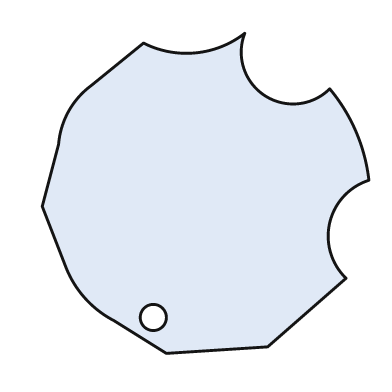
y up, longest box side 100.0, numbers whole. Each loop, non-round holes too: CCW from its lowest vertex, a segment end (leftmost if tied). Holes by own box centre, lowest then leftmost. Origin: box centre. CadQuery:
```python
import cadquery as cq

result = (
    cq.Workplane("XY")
    .moveTo(-12.0, -49.0)
    .lineTo(19.0, -47.0)
    .lineTo(43.0, -26.0)
    .threePointArc((38.0, -9.0), (50.0, 4.0))
    .threePointArc((46.0, 19.0), (38.0, 32.0))
    .threePointArc((18.0, 30.0), (12.0, 49.0))
    .threePointArc((-3.0, 43.0), (-19.0, 46.0))
    .lineTo(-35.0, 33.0)
    .threePointArc((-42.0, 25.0), (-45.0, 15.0))
    .lineTo(-50.0, -4.0)
    .lineTo(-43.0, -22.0)
    .threePointArc((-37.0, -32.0), (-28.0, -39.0))
    .close()
    .moveTo(-16.0, -38.0)
    .circle(4.0)
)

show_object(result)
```